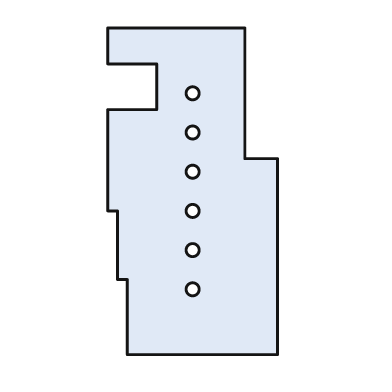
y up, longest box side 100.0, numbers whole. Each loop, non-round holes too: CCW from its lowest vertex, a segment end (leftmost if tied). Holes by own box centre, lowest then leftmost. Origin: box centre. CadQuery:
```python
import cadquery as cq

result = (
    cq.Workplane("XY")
    .moveTo(-20.0, -50.0)
    .lineTo(26.0, -50.0)
    .lineTo(26.0, 10.0)
    .lineTo(16.0, 10.0)
    .lineTo(16.0, 50.0)
    .lineTo(-26.0, 50.0)
    .lineTo(-26.0, 39.0)
    .lineTo(-11.0, 39.0)
    .lineTo(-11.0, 25.0)
    .lineTo(-26.0, 25.0)
    .lineTo(-26.0, -6.0)
    .lineTo(-23.0, -6.0)
    .lineTo(-23.0, -27.0)
    .lineTo(-20.0, -27.0)
    .close()
    .moveTo(0.0, -30.0)
    .circle(2.0)
    .moveTo(0.0, -18.0)
    .circle(2.0)
    .moveTo(0.0, -6.0)
    .circle(2.0)
    .moveTo(0.0, 6.0)
    .circle(2.0)
    .moveTo(0.0, 18.0)
    .circle(2.0)
    .moveTo(0.0, 30.0)
    .circle(2.0)
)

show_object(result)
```